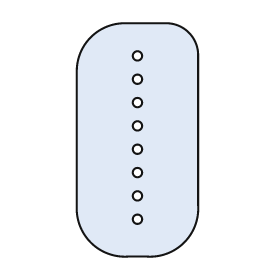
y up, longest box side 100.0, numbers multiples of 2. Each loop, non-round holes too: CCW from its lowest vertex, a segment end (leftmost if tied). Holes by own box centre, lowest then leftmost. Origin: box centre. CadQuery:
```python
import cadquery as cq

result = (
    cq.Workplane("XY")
    .moveTo(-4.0, -50.0)
    .lineTo(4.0, -50.0)
    .threePointArc((20.0, -44.0), (26.0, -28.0))
    .lineTo(26.0, 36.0)
    .threePointArc((22.0, 46.0), (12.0, 50.0))
    .lineTo(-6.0, 50.0)
    .threePointArc((-20.0, 44.0), (-26.0, 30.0))
    .lineTo(-26.0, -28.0)
    .threePointArc((-20.0, -44.0), (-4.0, -50.0))
    .close()
    .moveTo(0.0, -34.0)
    .circle(2.0)
    .moveTo(0.0, -24.0)
    .circle(2.0)
    .moveTo(0.0, -14.0)
    .circle(2.0)
    .moveTo(0.0, -4.0)
    .circle(2.0)
    .moveTo(0.0, 6.0)
    .circle(2.0)
    .moveTo(0.0, 16.0)
    .circle(2.0)
    .moveTo(0.0, 26.0)
    .circle(2.0)
    .moveTo(0.0, 36.0)
    .circle(2.0)
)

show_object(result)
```